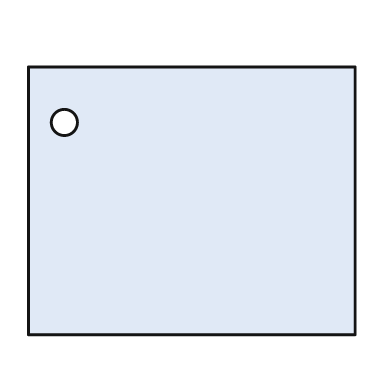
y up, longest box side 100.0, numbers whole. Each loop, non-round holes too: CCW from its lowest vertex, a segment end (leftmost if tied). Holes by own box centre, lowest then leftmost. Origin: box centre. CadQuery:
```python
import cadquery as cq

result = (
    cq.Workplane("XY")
    .moveTo(-50.0, -41.0)
    .lineTo(50.0, -41.0)
    .lineTo(50.0, 41.0)
    .lineTo(-50.0, 41.0)
    .close()
    .moveTo(-39.0, 24.0)
    .circle(4.0)
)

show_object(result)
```